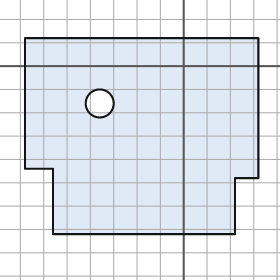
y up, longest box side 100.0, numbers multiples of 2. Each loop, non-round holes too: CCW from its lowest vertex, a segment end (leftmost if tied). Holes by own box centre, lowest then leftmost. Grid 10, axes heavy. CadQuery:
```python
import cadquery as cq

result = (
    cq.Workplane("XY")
    .moveTo(-56.0, -72.0)
    .lineTo(22.0, -72.0)
    .lineTo(22.0, -48.0)
    .lineTo(32.0, -48.0)
    .lineTo(32.0, 12.0)
    .lineTo(-68.0, 12.0)
    .lineTo(-68.0, -44.0)
    .lineTo(-56.0, -44.0)
    .close()
    .moveTo(-36.0, -16.0)
    .circle(6.0)
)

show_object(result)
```